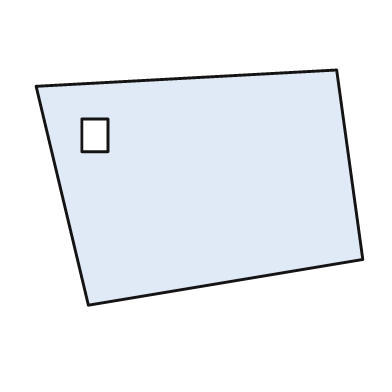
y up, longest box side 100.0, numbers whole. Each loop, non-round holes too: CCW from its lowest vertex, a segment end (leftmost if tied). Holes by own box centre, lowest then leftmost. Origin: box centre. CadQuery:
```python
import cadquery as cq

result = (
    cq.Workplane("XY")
    .moveTo(-34.0, -36.0)
    .lineTo(50.0, -22.0)
    .lineTo(42.0, 36.0)
    .lineTo(-50.0, 31.0)
    .close()
    .moveTo(-36.0, 11.0)
    .lineTo(-28.0, 11.0)
    .lineTo(-28.0, 21.0)
    .lineTo(-36.0, 21.0)
    .close()
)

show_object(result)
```